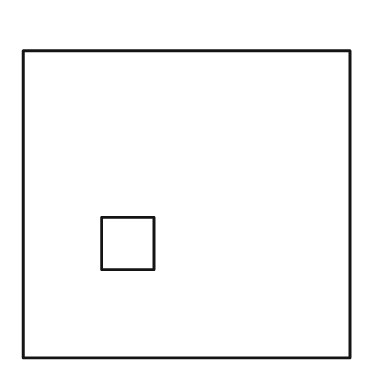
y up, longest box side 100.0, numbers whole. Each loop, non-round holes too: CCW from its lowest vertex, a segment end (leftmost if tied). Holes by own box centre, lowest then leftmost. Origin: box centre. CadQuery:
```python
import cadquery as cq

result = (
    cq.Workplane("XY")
    .moveTo(-50.0, -47.0)
    .lineTo(50.0, -47.0)
    .lineTo(50.0, 47.0)
    .lineTo(-50.0, 47.0)
    .close()
    .moveTo(-26.0, -20.0)
    .lineTo(-10.0, -20.0)
    .lineTo(-10.0, -4.0)
    .lineTo(-26.0, -4.0)
    .close()
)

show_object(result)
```